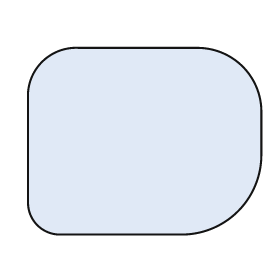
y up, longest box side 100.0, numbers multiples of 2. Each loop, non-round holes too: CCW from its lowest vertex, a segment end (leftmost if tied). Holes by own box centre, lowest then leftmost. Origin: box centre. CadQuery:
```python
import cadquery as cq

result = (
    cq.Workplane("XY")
    .moveTo(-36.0, -40.0)
    .lineTo(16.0, -40.0)
    .threePointArc((40.0, -30.0), (50.0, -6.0))
    .lineTo(50.0, 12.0)
    .threePointArc((42.0, 32.0), (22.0, 40.0))
    .lineTo(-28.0, 40.0)
    .threePointArc((-44.0, 34.0), (-50.0, 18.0))
    .lineTo(-50.0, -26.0)
    .threePointArc((-46.0, -36.0), (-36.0, -40.0))
    .close()
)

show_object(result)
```